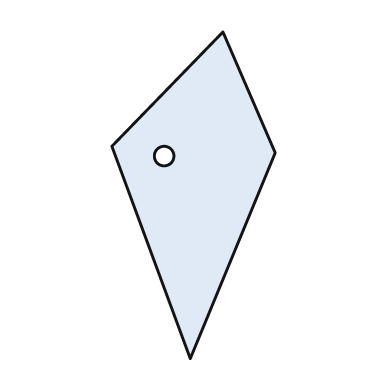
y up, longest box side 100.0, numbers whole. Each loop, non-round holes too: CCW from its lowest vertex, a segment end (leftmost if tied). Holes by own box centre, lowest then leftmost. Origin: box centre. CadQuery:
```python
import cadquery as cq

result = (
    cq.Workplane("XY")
    .moveTo(-1.0, -50.0)
    .lineTo(25.0, 13.0)
    .lineTo(9.0, 50.0)
    .lineTo(-25.0, 15.0)
    .close()
    .moveTo(-9.0, 12.0)
    .circle(3.0)
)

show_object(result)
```